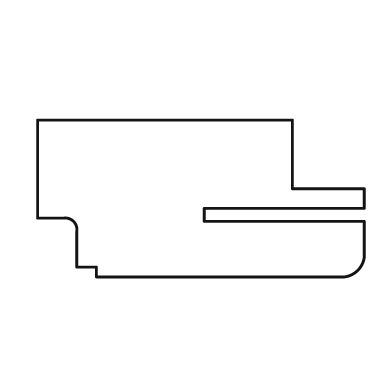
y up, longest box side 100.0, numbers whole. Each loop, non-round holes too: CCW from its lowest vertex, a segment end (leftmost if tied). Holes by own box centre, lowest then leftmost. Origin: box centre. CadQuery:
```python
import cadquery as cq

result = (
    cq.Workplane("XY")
    .moveTo(-32.0, -24.0)
    .lineTo(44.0, -24.0)
    .threePointArc((48.0, -22.0), (50.0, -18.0))
    .lineTo(50.0, -7.0)
    .lineTo(1.0, -7.0)
    .lineTo(1.0, -3.0)
    .lineTo(50.0, -3.0)
    .lineTo(50.0, 3.0)
    .lineTo(28.0, 3.0)
    .lineTo(28.0, 24.0)
    .lineTo(-50.0, 24.0)
    .lineTo(-50.0, -6.0)
    .lineTo(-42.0, -6.0)
    .threePointArc((-39.0, -7.0), (-38.0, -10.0))
    .lineTo(-38.0, -21.0)
    .lineTo(-32.0, -21.0)
    .close()
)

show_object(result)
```